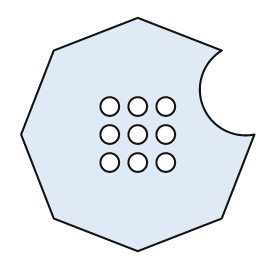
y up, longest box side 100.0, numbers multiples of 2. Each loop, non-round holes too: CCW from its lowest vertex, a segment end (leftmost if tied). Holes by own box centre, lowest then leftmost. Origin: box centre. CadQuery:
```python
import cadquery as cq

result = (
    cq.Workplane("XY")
    .moveTo(0.0, -50.0)
    .lineTo(36.0, -36.0)
    .lineTo(50.0, 0.0)
    .threePointArc((28.0, 12.0), (36.0, 36.0))
    .lineTo(0.0, 50.0)
    .lineTo(-36.0, 36.0)
    .lineTo(-50.0, 0.0)
    .lineTo(-36.0, -36.0)
    .close()
    .moveTo(-12.0, -12.0)
    .circle(4.0)
    .moveTo(0.0, -12.0)
    .circle(4.0)
    .moveTo(12.0, -12.0)
    .circle(4.0)
    .moveTo(-12.0, 0.0)
    .circle(4.0)
    .moveTo(0.0, 0.0)
    .circle(4.0)
    .moveTo(12.0, 0.0)
    .circle(4.0)
    .moveTo(-12.0, 12.0)
    .circle(4.0)
    .moveTo(0.0, 12.0)
    .circle(4.0)
    .moveTo(12.0, 12.0)
    .circle(4.0)
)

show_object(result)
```